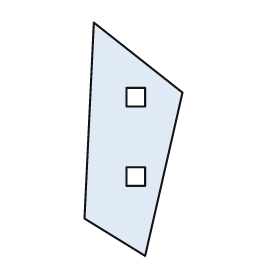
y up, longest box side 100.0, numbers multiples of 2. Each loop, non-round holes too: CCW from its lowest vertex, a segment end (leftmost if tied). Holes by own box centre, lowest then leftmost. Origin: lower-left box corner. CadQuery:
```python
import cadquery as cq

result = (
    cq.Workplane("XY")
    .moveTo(26.0, 0.0)
    .lineTo(42.0, 70.0)
    .lineTo(4.0, 100.0)
    .lineTo(0.0, 16.0)
    .close()
    .moveTo(18.0, 30.0)
    .lineTo(26.0, 30.0)
    .lineTo(26.0, 38.0)
    .lineTo(18.0, 38.0)
    .close()
    .moveTo(18.0, 64.0)
    .lineTo(26.0, 64.0)
    .lineTo(26.0, 72.0)
    .lineTo(18.0, 72.0)
    .close()
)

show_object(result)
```